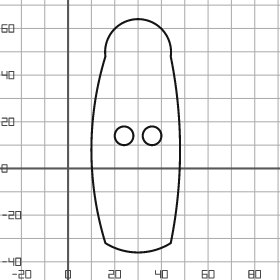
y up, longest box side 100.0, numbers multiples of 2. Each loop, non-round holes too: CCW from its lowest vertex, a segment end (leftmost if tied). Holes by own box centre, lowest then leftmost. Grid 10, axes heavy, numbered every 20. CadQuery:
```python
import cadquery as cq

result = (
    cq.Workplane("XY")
    .moveTo(16.0, -32.0)
    .threePointArc((30.0, -36.0), (44.0, -32.0))
    .threePointArc((48.0, 8.0), (44.0, 48.0))
    .threePointArc((30.0, 64.0), (16.0, 48.0))
    .threePointArc((10.0, 8.0), (16.0, -32.0))
    .close()
    .moveTo(24.0, 14.0)
    .circle(4.0)
    .moveTo(36.0, 14.0)
    .circle(4.0)
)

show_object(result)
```